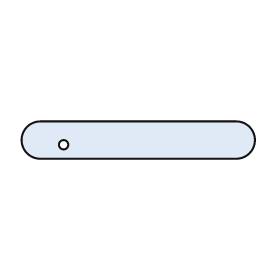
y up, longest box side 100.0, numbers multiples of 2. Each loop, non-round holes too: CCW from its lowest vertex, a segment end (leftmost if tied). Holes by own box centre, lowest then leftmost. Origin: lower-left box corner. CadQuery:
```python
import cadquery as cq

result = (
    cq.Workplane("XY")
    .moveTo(8.0, 0.0)
    .lineTo(92.0, 0.0)
    .threePointArc((100.0, 8.0), (92.0, 16.0))
    .lineTo(8.0, 16.0)
    .threePointArc((0.0, 8.0), (8.0, 0.0))
    .close()
    .moveTo(18.0, 6.0)
    .circle(2.0)
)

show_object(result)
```